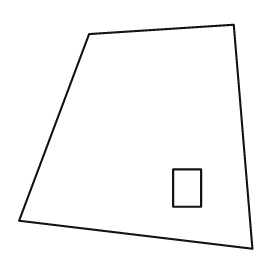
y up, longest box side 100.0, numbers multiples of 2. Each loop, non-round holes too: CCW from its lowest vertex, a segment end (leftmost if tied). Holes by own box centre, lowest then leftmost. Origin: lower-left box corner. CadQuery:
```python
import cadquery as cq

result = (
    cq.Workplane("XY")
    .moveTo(100.0, 0.0)
    .lineTo(92.0, 96.0)
    .lineTo(30.0, 92.0)
    .lineTo(0.0, 12.0)
    .close()
    .moveTo(66.0, 18.0)
    .lineTo(78.0, 18.0)
    .lineTo(78.0, 34.0)
    .lineTo(66.0, 34.0)
    .close()
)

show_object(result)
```